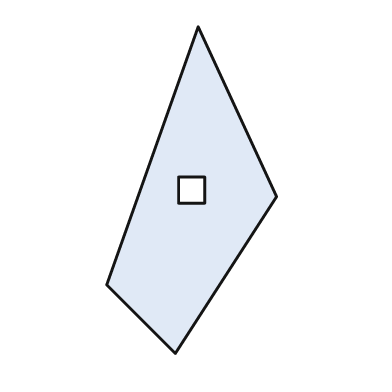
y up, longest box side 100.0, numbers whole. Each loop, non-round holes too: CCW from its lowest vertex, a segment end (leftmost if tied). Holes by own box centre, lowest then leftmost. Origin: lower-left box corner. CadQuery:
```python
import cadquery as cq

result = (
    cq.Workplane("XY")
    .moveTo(21.0, 0.0)
    .lineTo(52.0, 48.0)
    .lineTo(28.0, 100.0)
    .lineTo(0.0, 21.0)
    .close()
    .moveTo(22.0, 46.0)
    .lineTo(30.0, 46.0)
    .lineTo(30.0, 54.0)
    .lineTo(22.0, 54.0)
    .close()
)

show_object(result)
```